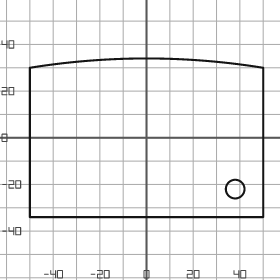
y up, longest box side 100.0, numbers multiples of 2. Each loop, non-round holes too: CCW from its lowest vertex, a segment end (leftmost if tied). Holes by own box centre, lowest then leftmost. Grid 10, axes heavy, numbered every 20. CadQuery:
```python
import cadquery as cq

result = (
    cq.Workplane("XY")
    .moveTo(-50.0, -34.0)
    .lineTo(50.0, -34.0)
    .lineTo(50.0, 30.0)
    .threePointArc((0.0, 34.0), (-50.0, 30.0))
    .close()
    .moveTo(38.0, -22.0)
    .circle(4.0)
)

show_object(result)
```